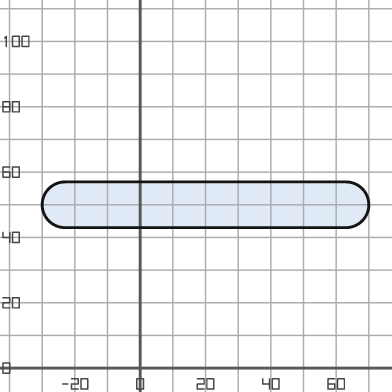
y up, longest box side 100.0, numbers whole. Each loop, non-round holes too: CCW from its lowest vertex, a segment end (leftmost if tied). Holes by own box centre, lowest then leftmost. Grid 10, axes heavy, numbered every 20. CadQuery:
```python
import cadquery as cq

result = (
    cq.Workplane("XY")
    .moveTo(-23.0, 43.0)
    .lineTo(63.0, 43.0)
    .threePointArc((70.0, 50.0), (63.0, 57.0))
    .lineTo(-23.0, 57.0)
    .threePointArc((-30.0, 50.0), (-23.0, 43.0))
    .close()
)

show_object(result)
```